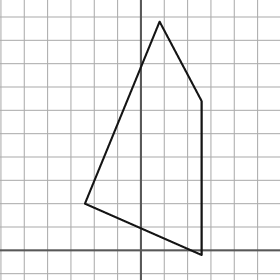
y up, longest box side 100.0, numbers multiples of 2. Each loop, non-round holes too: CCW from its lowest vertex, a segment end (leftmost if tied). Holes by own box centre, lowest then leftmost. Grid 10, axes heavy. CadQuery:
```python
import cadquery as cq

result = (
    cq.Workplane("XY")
    .moveTo(26.0, -2.0)
    .lineTo(26.0, 64.0)
    .lineTo(8.0, 98.0)
    .lineTo(-24.0, 20.0)
    .close()
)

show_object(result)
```